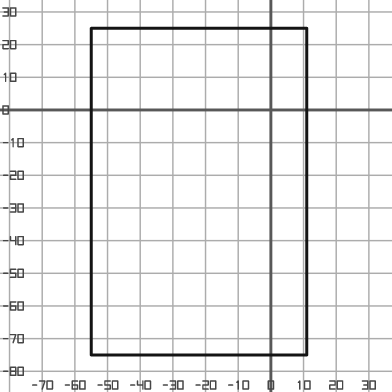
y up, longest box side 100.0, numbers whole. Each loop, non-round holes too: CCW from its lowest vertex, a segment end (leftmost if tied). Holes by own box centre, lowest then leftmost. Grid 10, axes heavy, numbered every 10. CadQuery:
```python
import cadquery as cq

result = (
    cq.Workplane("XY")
    .moveTo(-55.0, -75.0)
    .lineTo(11.0, -75.0)
    .lineTo(11.0, 25.0)
    .lineTo(-55.0, 25.0)
    .close()
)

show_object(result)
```